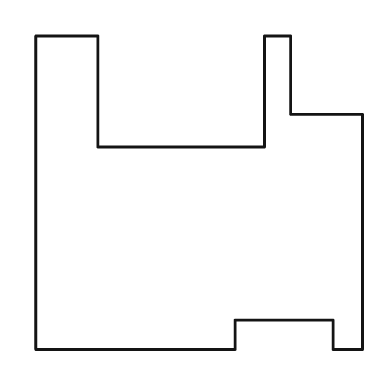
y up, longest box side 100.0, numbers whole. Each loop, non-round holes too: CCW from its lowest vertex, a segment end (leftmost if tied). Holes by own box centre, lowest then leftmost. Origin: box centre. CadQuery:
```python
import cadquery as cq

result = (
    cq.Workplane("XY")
    .moveTo(-50.0, -48.0)
    .lineTo(11.0, -48.0)
    .lineTo(11.0, -39.0)
    .lineTo(41.0, -39.0)
    .lineTo(41.0, -48.0)
    .lineTo(50.0, -48.0)
    .lineTo(50.0, 24.0)
    .lineTo(28.0, 24.0)
    .lineTo(28.0, 48.0)
    .lineTo(20.0, 48.0)
    .lineTo(20.0, 14.0)
    .lineTo(-31.0, 14.0)
    .lineTo(-31.0, 48.0)
    .lineTo(-50.0, 48.0)
    .close()
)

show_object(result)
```